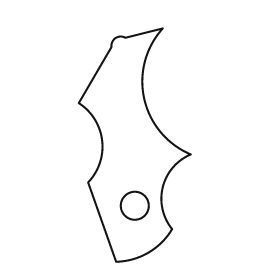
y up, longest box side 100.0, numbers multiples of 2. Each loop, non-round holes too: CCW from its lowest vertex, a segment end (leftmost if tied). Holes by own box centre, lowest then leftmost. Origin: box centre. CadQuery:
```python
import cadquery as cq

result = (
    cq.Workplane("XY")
    .moveTo(-8.0, -50.0)
    .threePointArc((6.0, -46.0), (16.0, -36.0))
    .threePointArc((12.0, -18.0), (24.0, -4.0))
    .threePointArc((4.0, 20.0), (12.0, 50.0))
    .lineTo(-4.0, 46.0)
    .threePointArc((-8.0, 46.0), (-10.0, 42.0))
    .lineTo(-24.0, 18.0)
    .threePointArc((-14.0, 2.0), (-20.0, -16.0))
    .close()
    .moveTo(0.0, -26.0)
    .circle(6.0)
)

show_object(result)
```